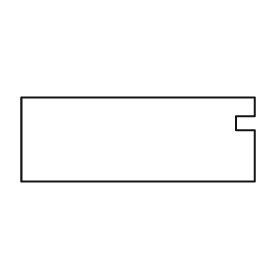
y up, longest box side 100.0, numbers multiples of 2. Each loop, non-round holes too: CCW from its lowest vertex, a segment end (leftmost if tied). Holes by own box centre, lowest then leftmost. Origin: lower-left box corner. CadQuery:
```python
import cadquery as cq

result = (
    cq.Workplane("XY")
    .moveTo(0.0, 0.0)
    .lineTo(100.0, 0.0)
    .lineTo(100.0, 22.0)
    .lineTo(92.0, 22.0)
    .lineTo(92.0, 28.0)
    .lineTo(100.0, 28.0)
    .lineTo(100.0, 36.0)
    .lineTo(0.0, 36.0)
    .close()
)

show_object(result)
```